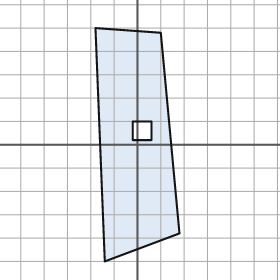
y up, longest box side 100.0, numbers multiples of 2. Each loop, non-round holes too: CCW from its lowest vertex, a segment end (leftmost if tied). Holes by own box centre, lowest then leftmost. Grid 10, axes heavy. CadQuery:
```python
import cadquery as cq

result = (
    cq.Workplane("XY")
    .moveTo(-14.0, -50.0)
    .lineTo(18.0, -38.0)
    .lineTo(10.0, 48.0)
    .lineTo(-18.0, 50.0)
    .close()
    .moveTo(-2.0, 2.0)
    .lineTo(6.0, 2.0)
    .lineTo(6.0, 10.0)
    .lineTo(-2.0, 10.0)
    .close()
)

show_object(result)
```